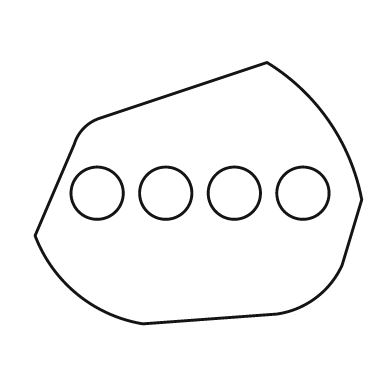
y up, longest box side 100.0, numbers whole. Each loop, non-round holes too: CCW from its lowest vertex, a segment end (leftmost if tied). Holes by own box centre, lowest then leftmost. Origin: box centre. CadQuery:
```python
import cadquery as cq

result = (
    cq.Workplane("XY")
    .moveTo(-17.0, -40.0)
    .lineTo(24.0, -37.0)
    .threePointArc((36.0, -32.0), (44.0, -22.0))
    .lineTo(50.0, -2.0)
    .threePointArc((40.0, 22.0), (21.0, 40.0))
    .lineTo(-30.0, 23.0)
    .threePointArc((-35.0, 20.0), (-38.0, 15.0))
    .lineTo(-50.0, -13.0)
    .threePointArc((-37.0, -31.0), (-17.0, -40.0))
    .close()
    .moveTo(-31.0, 0.0)
    .circle(8.0)
    .moveTo(-10.0, 0.0)
    .circle(8.0)
    .moveTo(11.0, 0.0)
    .circle(8.0)
    .moveTo(32.0, 0.0)
    .circle(8.0)
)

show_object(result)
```